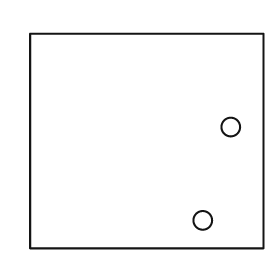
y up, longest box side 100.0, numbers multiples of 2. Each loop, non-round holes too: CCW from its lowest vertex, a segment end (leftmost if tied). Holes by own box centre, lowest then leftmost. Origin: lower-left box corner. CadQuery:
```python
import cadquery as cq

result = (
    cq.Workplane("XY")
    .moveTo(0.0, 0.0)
    .lineTo(100.0, 0.0)
    .lineTo(100.0, 92.0)
    .lineTo(0.0, 92.0)
    .close()
    .moveTo(74.0, 12.0)
    .circle(4.0)
    .moveTo(86.0, 52.0)
    .circle(4.0)
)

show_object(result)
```